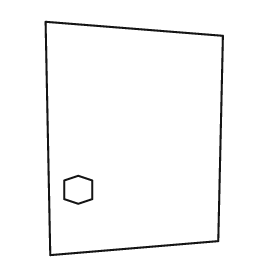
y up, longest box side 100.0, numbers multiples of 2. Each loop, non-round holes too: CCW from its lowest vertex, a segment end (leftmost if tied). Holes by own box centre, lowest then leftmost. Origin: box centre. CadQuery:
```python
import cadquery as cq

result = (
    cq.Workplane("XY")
    .moveTo(-36.0, -50.0)
    .lineTo(36.0, -44.0)
    .lineTo(38.0, 44.0)
    .lineTo(-38.0, 50.0)
    .close()
    .moveTo(-24.0, -28.0)
    .lineTo(-18.0, -26.0)
    .lineTo(-18.0, -18.0)
    .lineTo(-24.0, -16.0)
    .lineTo(-30.0, -18.0)
    .lineTo(-30.0, -26.0)
    .close()
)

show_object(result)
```